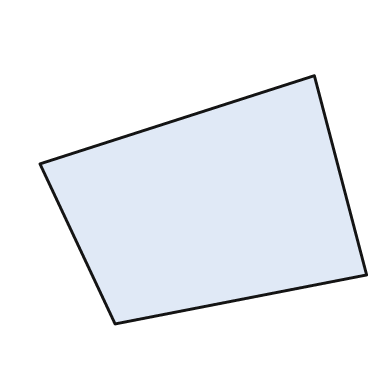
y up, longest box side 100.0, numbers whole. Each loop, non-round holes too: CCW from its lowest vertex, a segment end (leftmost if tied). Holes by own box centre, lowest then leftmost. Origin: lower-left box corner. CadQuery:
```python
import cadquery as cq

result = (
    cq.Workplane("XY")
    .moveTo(23.0, 0.0)
    .lineTo(100.0, 15.0)
    .lineTo(84.0, 76.0)
    .lineTo(0.0, 49.0)
    .close()
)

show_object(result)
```